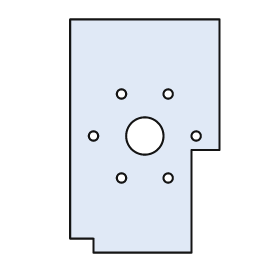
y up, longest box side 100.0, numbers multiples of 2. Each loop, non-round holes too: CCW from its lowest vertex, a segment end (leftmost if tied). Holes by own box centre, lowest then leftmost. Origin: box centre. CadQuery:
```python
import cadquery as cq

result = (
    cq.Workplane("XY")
    .moveTo(-22.0, -50.0)
    .lineTo(20.0, -50.0)
    .lineTo(20.0, -6.0)
    .lineTo(32.0, -6.0)
    .lineTo(32.0, 50.0)
    .lineTo(-32.0, 50.0)
    .lineTo(-32.0, -44.0)
    .lineTo(-22.0, -44.0)
    .close()
    .moveTo(-10.0, -18.0)
    .circle(2.0)
    .moveTo(10.0, -18.0)
    .circle(2.0)
    .moveTo(-22.0, 0.0)
    .circle(2.0)
    .moveTo(0.0, 0.0)
    .circle(8.0)
    .moveTo(22.0, 0.0)
    .circle(2.0)
    .moveTo(-10.0, 18.0)
    .circle(2.0)
    .moveTo(10.0, 18.0)
    .circle(2.0)
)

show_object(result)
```